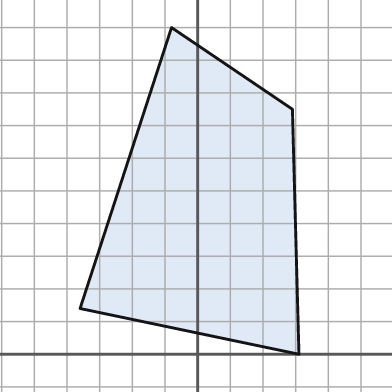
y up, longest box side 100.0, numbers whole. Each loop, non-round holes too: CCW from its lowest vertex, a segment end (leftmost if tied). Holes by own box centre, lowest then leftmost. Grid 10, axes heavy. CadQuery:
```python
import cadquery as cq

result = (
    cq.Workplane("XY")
    .moveTo(31.0, 0.0)
    .lineTo(29.0, 75.0)
    .lineTo(-8.0, 100.0)
    .lineTo(-36.0, 14.0)
    .close()
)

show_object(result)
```